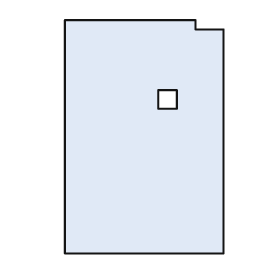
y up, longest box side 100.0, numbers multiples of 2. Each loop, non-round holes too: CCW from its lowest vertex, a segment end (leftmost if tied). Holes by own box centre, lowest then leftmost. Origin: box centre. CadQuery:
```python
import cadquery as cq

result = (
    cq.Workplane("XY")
    .moveTo(-34.0, -50.0)
    .lineTo(34.0, -50.0)
    .lineTo(34.0, 46.0)
    .lineTo(22.0, 46.0)
    .lineTo(22.0, 50.0)
    .lineTo(-34.0, 50.0)
    .close()
    .moveTo(6.0, 12.0)
    .lineTo(14.0, 12.0)
    .lineTo(14.0, 20.0)
    .lineTo(6.0, 20.0)
    .close()
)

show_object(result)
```